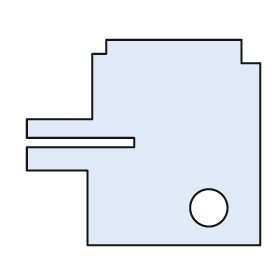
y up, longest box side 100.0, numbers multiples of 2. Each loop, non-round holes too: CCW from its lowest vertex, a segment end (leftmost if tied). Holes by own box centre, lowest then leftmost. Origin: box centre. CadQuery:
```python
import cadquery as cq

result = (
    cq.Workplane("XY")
    .moveTo(-24.0, -44.0)
    .lineTo(50.0, -44.0)
    .lineTo(50.0, 34.0)
    .lineTo(42.0, 34.0)
    .lineTo(42.0, 44.0)
    .lineTo(-16.0, 44.0)
    .lineTo(-16.0, 38.0)
    .lineTo(-22.0, 38.0)
    .lineTo(-22.0, 10.0)
    .lineTo(-50.0, 10.0)
    .lineTo(-50.0, 2.0)
    .lineTo(-4.0, 2.0)
    .lineTo(-4.0, -2.0)
    .lineTo(-50.0, -2.0)
    .lineTo(-50.0, -12.0)
    .lineTo(-24.0, -12.0)
    .close()
    .moveTo(28.0, -28.0)
    .circle(8.0)
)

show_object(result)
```